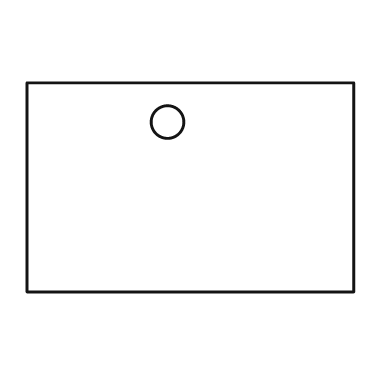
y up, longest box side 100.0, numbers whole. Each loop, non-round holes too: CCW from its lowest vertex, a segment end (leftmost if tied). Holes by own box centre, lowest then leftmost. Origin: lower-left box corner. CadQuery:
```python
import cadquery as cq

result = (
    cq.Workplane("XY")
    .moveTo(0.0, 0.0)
    .lineTo(100.0, 0.0)
    .lineTo(100.0, 64.0)
    .lineTo(0.0, 64.0)
    .close()
    .moveTo(43.0, 52.0)
    .circle(5.0)
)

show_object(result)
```